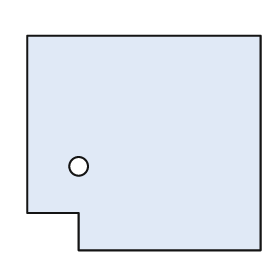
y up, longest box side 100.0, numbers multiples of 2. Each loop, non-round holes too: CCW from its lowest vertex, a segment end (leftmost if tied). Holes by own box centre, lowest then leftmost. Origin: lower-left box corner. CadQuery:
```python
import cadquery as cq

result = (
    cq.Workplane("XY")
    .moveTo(22.0, 0.0)
    .lineTo(100.0, 0.0)
    .lineTo(100.0, 92.0)
    .lineTo(0.0, 92.0)
    .lineTo(0.0, 16.0)
    .lineTo(22.0, 16.0)
    .close()
    .moveTo(22.0, 36.0)
    .circle(4.0)
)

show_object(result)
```